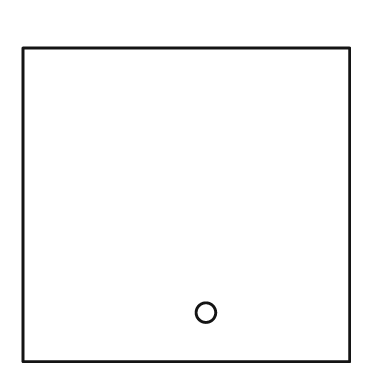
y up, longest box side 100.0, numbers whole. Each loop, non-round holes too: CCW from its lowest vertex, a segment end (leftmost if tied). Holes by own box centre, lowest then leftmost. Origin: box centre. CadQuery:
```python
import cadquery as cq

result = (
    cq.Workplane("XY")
    .moveTo(-50.0, -48.0)
    .lineTo(50.0, -48.0)
    .lineTo(50.0, 48.0)
    .lineTo(-50.0, 48.0)
    .close()
    .moveTo(6.0, -33.0)
    .circle(3.0)
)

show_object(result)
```